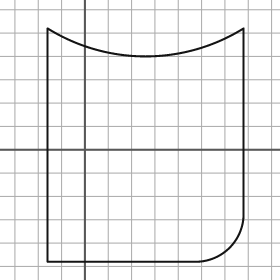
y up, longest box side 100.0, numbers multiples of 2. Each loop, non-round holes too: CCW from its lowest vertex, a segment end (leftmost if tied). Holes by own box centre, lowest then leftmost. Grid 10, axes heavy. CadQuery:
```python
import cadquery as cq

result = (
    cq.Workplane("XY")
    .moveTo(-16.0, -48.0)
    .lineTo(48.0, -48.0)
    .threePointArc((62.0, -42.0), (68.0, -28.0))
    .lineTo(68.0, 52.0)
    .threePointArc((26.0, 40.0), (-16.0, 52.0))
    .close()
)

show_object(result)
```